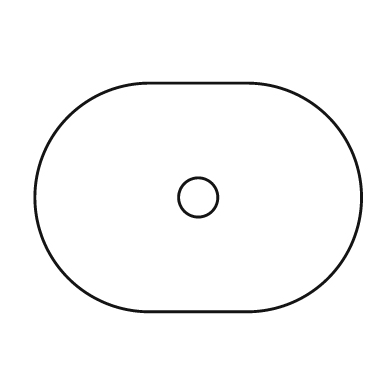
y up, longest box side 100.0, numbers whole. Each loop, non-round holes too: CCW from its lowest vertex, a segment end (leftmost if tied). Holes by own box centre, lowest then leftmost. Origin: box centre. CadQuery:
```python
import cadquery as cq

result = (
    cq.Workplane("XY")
    .moveTo(-15.0, -35.0)
    .lineTo(15.0, -35.0)
    .threePointArc((50.0, 0.0), (15.0, 35.0))
    .lineTo(-15.0, 35.0)
    .threePointArc((-50.0, 0.0), (-15.0, -35.0))
    .close()
    .moveTo(0.0, 0.0)
    .circle(6.0)
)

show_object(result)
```